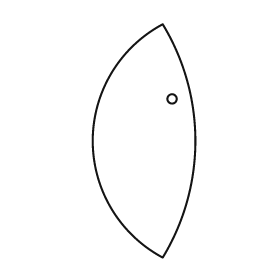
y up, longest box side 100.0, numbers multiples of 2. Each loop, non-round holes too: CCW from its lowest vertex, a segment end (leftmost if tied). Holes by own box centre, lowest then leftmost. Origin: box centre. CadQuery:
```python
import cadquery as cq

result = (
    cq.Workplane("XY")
    .moveTo(8.0, -50.0)
    .threePointArc((22.0, 0.0), (8.0, 50.0))
    .threePointArc((-22.0, 0.0), (8.0, -50.0))
    .close()
    .moveTo(12.0, 18.0)
    .circle(2.0)
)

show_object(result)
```